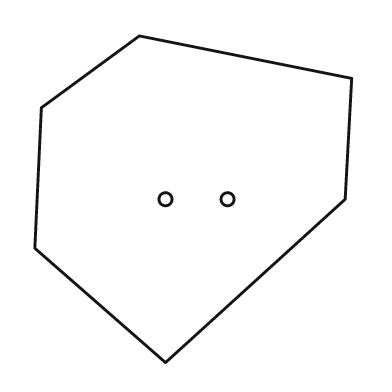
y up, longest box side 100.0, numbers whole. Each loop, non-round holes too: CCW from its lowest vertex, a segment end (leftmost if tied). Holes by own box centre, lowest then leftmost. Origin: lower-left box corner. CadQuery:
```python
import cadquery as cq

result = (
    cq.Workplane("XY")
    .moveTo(40.0, 0.0)
    .lineTo(95.0, 50.0)
    .lineTo(97.0, 87.0)
    .lineTo(32.0, 100.0)
    .lineTo(2.0, 78.0)
    .lineTo(0.0, 35.0)
    .close()
    .moveTo(40.0, 50.0)
    .circle(2.0)
    .moveTo(59.0, 50.0)
    .circle(2.0)
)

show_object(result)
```